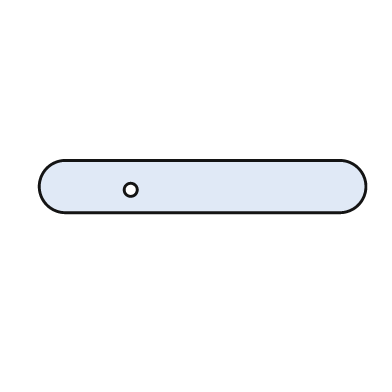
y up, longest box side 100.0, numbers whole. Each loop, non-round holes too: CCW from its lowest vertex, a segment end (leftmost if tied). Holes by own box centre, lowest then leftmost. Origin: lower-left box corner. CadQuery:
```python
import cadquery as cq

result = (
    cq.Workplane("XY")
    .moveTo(8.0, 0.0)
    .lineTo(92.0, 0.0)
    .threePointArc((100.0, 8.0), (92.0, 16.0))
    .lineTo(8.0, 16.0)
    .threePointArc((0.0, 8.0), (8.0, 0.0))
    .close()
    .moveTo(28.0, 7.0)
    .circle(2.0)
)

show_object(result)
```